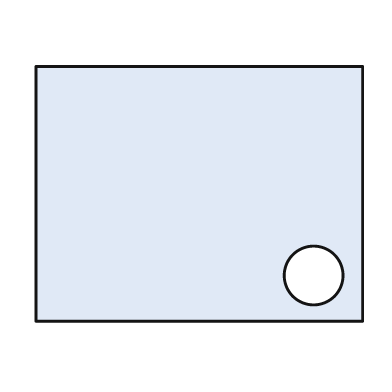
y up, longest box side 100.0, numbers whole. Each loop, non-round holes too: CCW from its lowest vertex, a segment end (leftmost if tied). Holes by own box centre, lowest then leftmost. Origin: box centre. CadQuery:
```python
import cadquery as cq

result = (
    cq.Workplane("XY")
    .moveTo(-50.0, -39.0)
    .lineTo(50.0, -39.0)
    .lineTo(50.0, 39.0)
    .lineTo(-50.0, 39.0)
    .close()
    .moveTo(35.0, -25.0)
    .circle(9.0)
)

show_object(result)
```